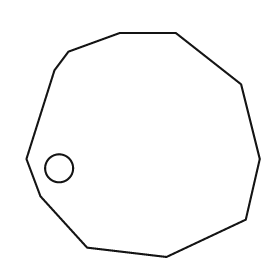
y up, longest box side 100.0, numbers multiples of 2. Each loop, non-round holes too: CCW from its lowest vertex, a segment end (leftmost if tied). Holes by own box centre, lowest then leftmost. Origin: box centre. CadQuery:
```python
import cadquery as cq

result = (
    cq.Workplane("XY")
    .moveTo(10.0, -48.0)
    .lineTo(44.0, -32.0)
    .lineTo(50.0, -6.0)
    .lineTo(42.0, 26.0)
    .lineTo(14.0, 48.0)
    .lineTo(-10.0, 48.0)
    .lineTo(-32.0, 40.0)
    .lineTo(-38.0, 32.0)
    .lineTo(-50.0, -6.0)
    .lineTo(-44.0, -22.0)
    .lineTo(-24.0, -44.0)
    .close()
    .moveTo(-36.0, -10.0)
    .circle(6.0)
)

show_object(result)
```